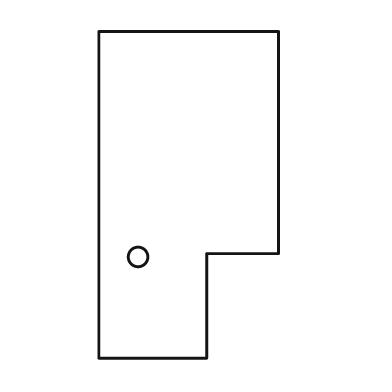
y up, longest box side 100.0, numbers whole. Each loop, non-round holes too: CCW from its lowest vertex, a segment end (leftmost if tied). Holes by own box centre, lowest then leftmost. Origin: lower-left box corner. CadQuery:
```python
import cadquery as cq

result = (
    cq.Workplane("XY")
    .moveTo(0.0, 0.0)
    .lineTo(33.0, 0.0)
    .lineTo(33.0, 32.0)
    .lineTo(55.0, 32.0)
    .lineTo(55.0, 100.0)
    .lineTo(0.0, 100.0)
    .close()
    .moveTo(12.0, 31.0)
    .circle(3.0)
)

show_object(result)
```